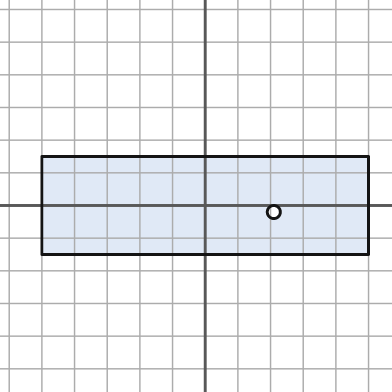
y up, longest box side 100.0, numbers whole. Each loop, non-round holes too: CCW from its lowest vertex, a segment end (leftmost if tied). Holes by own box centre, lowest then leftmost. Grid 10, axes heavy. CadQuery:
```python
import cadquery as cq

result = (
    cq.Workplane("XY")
    .moveTo(-50.0, -15.0)
    .lineTo(50.0, -15.0)
    .lineTo(50.0, 15.0)
    .lineTo(-50.0, 15.0)
    .close()
    .moveTo(21.0, -2.0)
    .circle(2.0)
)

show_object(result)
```